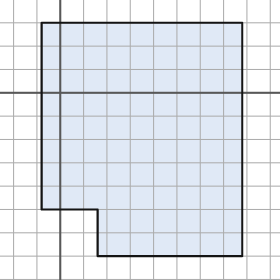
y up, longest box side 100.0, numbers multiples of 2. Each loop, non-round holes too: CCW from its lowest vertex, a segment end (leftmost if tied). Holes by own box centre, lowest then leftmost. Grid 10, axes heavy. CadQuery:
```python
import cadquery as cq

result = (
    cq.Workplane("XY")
    .moveTo(16.0, -70.0)
    .lineTo(78.0, -70.0)
    .lineTo(78.0, 30.0)
    .lineTo(-8.0, 30.0)
    .lineTo(-8.0, -50.0)
    .lineTo(16.0, -50.0)
    .close()
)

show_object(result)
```